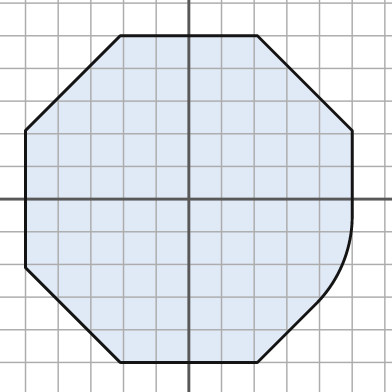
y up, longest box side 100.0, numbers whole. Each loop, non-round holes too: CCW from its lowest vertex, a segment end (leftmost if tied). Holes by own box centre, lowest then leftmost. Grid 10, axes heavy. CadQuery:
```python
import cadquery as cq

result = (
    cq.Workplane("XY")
    .moveTo(-21.0, -50.0)
    .lineTo(21.0, -50.0)
    .lineTo(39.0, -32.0)
    .threePointArc((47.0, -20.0), (50.0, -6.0))
    .lineTo(50.0, 21.0)
    .lineTo(21.0, 50.0)
    .lineTo(-21.0, 50.0)
    .lineTo(-50.0, 21.0)
    .lineTo(-50.0, -21.0)
    .close()
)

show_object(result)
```